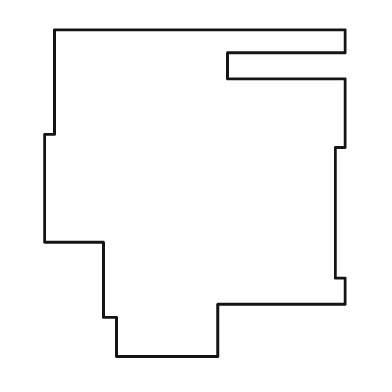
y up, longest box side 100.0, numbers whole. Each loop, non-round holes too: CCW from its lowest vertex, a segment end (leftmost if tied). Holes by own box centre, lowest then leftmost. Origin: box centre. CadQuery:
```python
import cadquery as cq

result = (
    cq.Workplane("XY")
    .moveTo(-24.0, -50.0)
    .lineTo(7.0, -50.0)
    .lineTo(7.0, -34.0)
    .lineTo(46.0, -34.0)
    .lineTo(46.0, -26.0)
    .lineTo(43.0, -26.0)
    .lineTo(43.0, 14.0)
    .lineTo(46.0, 14.0)
    .lineTo(46.0, 35.0)
    .lineTo(10.0, 35.0)
    .lineTo(10.0, 43.0)
    .lineTo(46.0, 43.0)
    .lineTo(46.0, 50.0)
    .lineTo(-43.0, 50.0)
    .lineTo(-43.0, 18.0)
    .lineTo(-46.0, 18.0)
    .lineTo(-46.0, -15.0)
    .lineTo(-28.0, -15.0)
    .lineTo(-28.0, -38.0)
    .lineTo(-24.0, -38.0)
    .close()
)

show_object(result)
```